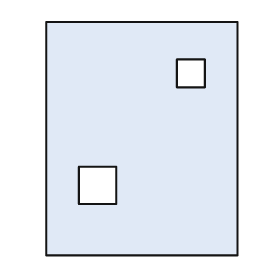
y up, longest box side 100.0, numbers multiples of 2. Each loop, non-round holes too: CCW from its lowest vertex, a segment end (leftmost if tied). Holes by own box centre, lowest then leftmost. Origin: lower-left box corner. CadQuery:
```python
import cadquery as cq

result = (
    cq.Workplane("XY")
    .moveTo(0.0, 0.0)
    .lineTo(82.0, 0.0)
    .lineTo(82.0, 100.0)
    .lineTo(0.0, 100.0)
    .close()
    .moveTo(14.0, 22.0)
    .lineTo(30.0, 22.0)
    .lineTo(30.0, 38.0)
    .lineTo(14.0, 38.0)
    .close()
    .moveTo(56.0, 72.0)
    .lineTo(68.0, 72.0)
    .lineTo(68.0, 84.0)
    .lineTo(56.0, 84.0)
    .close()
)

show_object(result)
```